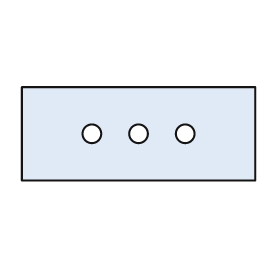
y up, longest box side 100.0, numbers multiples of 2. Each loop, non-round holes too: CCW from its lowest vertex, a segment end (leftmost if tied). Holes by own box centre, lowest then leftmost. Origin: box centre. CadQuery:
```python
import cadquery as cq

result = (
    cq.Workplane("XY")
    .moveTo(-50.0, -20.0)
    .lineTo(50.0, -20.0)
    .lineTo(50.0, 20.0)
    .lineTo(-50.0, 20.0)
    .close()
    .moveTo(-20.0, 0.0)
    .circle(4.0)
    .moveTo(0.0, 0.0)
    .circle(4.0)
    .moveTo(20.0, 0.0)
    .circle(4.0)
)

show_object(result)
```